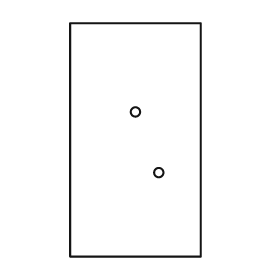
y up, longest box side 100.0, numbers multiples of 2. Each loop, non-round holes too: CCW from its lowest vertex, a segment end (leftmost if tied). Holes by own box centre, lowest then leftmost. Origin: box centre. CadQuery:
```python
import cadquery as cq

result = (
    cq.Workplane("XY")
    .moveTo(-28.0, -50.0)
    .lineTo(28.0, -50.0)
    .lineTo(28.0, 50.0)
    .lineTo(-28.0, 50.0)
    .close()
    .moveTo(10.0, -14.0)
    .circle(2.0)
    .moveTo(0.0, 12.0)
    .circle(2.0)
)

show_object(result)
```